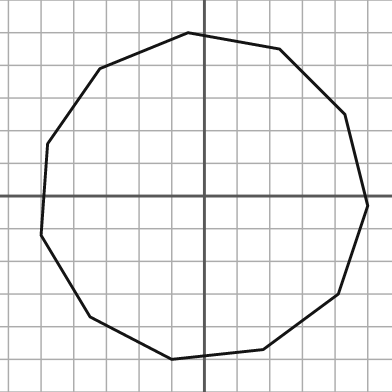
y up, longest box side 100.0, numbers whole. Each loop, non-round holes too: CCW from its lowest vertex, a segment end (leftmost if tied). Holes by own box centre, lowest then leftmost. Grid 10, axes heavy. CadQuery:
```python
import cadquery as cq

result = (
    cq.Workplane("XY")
    .moveTo(-10.0, -50.0)
    .lineTo(18.0, -47.0)
    .lineTo(41.0, -30.0)
    .lineTo(50.0, -3.0)
    .lineTo(43.0, 25.0)
    .lineTo(23.0, 45.0)
    .lineTo(-5.0, 50.0)
    .lineTo(-32.0, 39.0)
    .lineTo(-48.0, 16.0)
    .lineTo(-50.0, -12.0)
    .lineTo(-35.0, -37.0)
    .close()
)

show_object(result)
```